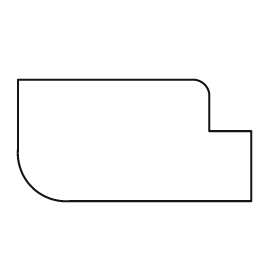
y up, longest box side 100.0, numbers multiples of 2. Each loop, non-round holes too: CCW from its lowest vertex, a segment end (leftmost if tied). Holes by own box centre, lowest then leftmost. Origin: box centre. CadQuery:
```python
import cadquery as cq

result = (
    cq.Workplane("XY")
    .moveTo(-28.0, -26.0)
    .lineTo(50.0, -26.0)
    .lineTo(50.0, 4.0)
    .lineTo(32.0, 4.0)
    .lineTo(32.0, 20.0)
    .threePointArc((30.0, 24.0), (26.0, 26.0))
    .lineTo(-50.0, 26.0)
    .lineTo(-50.0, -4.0)
    .threePointArc((-44.0, -20.0), (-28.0, -26.0))
    .close()
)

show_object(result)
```